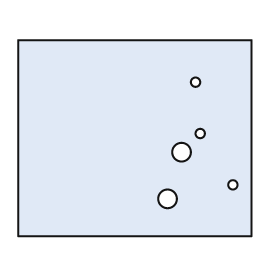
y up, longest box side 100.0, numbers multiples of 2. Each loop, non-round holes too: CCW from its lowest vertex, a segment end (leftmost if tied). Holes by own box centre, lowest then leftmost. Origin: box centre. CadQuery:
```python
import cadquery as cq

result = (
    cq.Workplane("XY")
    .moveTo(-50.0, -42.0)
    .lineTo(50.0, -42.0)
    .lineTo(50.0, 42.0)
    .lineTo(-50.0, 42.0)
    .close()
    .moveTo(14.0, -26.0)
    .circle(4.0)
    .moveTo(42.0, -20.0)
    .circle(2.0)
    .moveTo(20.0, -6.0)
    .circle(4.0)
    .moveTo(28.0, 2.0)
    .circle(2.0)
    .moveTo(26.0, 24.0)
    .circle(2.0)
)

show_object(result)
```